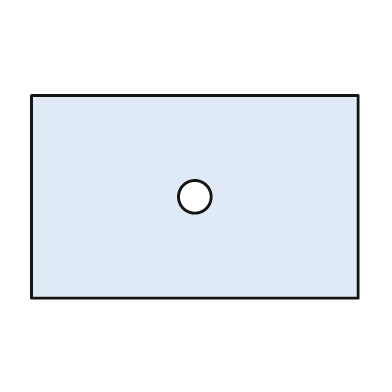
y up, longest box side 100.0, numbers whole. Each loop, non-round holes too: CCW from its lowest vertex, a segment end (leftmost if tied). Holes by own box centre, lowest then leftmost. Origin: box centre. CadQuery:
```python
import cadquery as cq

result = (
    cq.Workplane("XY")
    .moveTo(-50.0, -31.0)
    .lineTo(50.0, -31.0)
    .lineTo(50.0, 31.0)
    .lineTo(-50.0, 31.0)
    .close()
    .moveTo(0.0, 0.0)
    .circle(5.0)
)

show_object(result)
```